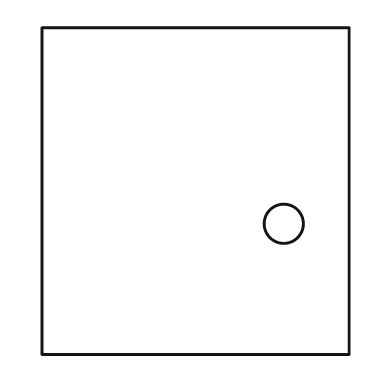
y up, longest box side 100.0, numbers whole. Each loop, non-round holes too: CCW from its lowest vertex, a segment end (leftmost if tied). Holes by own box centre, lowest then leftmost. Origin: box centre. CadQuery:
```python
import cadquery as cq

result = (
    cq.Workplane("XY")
    .moveTo(-47.0, -50.0)
    .lineTo(47.0, -50.0)
    .lineTo(47.0, 50.0)
    .lineTo(-47.0, 50.0)
    .close()
    .moveTo(27.0, -10.0)
    .circle(6.0)
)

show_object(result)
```